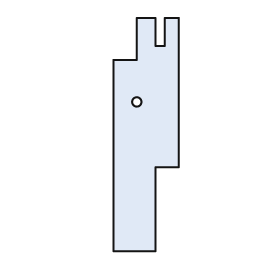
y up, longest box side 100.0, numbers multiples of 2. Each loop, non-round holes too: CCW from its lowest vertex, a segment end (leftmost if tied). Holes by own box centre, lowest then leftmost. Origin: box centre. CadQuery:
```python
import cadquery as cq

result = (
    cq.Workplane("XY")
    .moveTo(-14.0, -50.0)
    .lineTo(4.0, -50.0)
    .lineTo(4.0, -14.0)
    .lineTo(14.0, -14.0)
    .lineTo(14.0, 50.0)
    .lineTo(8.0, 50.0)
    .lineTo(8.0, 38.0)
    .lineTo(4.0, 38.0)
    .lineTo(4.0, 50.0)
    .lineTo(-4.0, 50.0)
    .lineTo(-4.0, 32.0)
    .lineTo(-14.0, 32.0)
    .close()
    .moveTo(-4.0, 14.0)
    .circle(2.0)
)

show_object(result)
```